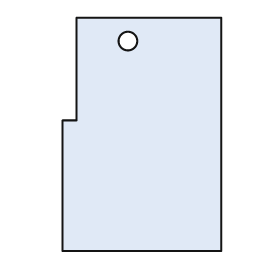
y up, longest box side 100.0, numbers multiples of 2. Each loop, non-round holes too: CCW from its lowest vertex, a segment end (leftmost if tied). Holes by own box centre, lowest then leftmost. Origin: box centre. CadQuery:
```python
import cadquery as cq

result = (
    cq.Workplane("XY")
    .moveTo(-34.0, -50.0)
    .lineTo(34.0, -50.0)
    .lineTo(34.0, 50.0)
    .lineTo(-28.0, 50.0)
    .lineTo(-28.0, 6.0)
    .lineTo(-34.0, 6.0)
    .close()
    .moveTo(-6.0, 40.0)
    .circle(4.0)
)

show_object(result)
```